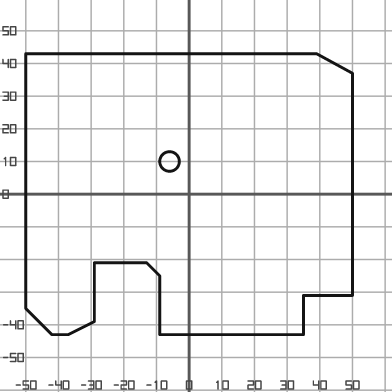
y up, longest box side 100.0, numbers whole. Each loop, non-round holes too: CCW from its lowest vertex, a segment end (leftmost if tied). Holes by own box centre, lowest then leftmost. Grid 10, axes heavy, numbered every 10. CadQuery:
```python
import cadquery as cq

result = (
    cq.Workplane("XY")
    .moveTo(-42.0, -43.0)
    .lineTo(-37.0, -43.0)
    .lineTo(-29.0, -39.0)
    .lineTo(-29.0, -21.0)
    .lineTo(-13.0, -21.0)
    .lineTo(-9.0, -25.0)
    .lineTo(-9.0, -43.0)
    .lineTo(35.0, -43.0)
    .lineTo(35.0, -31.0)
    .lineTo(50.0, -31.0)
    .lineTo(50.0, 37.0)
    .lineTo(39.0, 43.0)
    .lineTo(-50.0, 43.0)
    .lineTo(-50.0, -35.0)
    .close()
    .moveTo(-6.0, 10.0)
    .circle(3.0)
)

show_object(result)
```